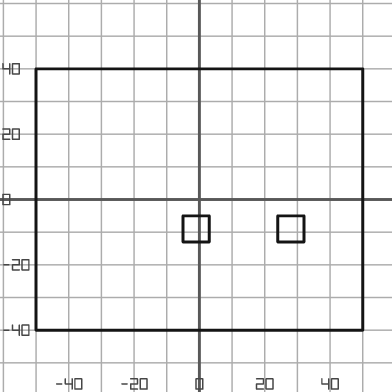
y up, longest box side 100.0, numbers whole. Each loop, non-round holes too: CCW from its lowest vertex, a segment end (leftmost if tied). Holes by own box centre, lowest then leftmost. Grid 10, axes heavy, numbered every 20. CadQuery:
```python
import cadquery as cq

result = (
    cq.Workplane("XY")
    .moveTo(-50.0, -40.0)
    .lineTo(50.0, -40.0)
    .lineTo(50.0, 40.0)
    .lineTo(-50.0, 40.0)
    .close()
    .moveTo(-5.0, -13.0)
    .lineTo(3.0, -13.0)
    .lineTo(3.0, -5.0)
    .lineTo(-5.0, -5.0)
    .close()
    .moveTo(24.0, -13.0)
    .lineTo(32.0, -13.0)
    .lineTo(32.0, -5.0)
    .lineTo(24.0, -5.0)
    .close()
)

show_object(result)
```